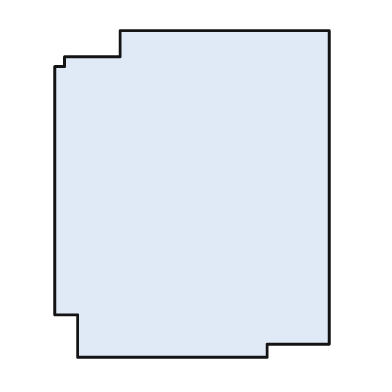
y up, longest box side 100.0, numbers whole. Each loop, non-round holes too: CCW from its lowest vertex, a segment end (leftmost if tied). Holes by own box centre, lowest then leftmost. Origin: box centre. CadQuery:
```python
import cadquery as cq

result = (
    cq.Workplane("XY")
    .moveTo(-35.0, -50.0)
    .lineTo(23.0, -50.0)
    .lineTo(23.0, -46.0)
    .lineTo(42.0, -46.0)
    .lineTo(42.0, 50.0)
    .lineTo(-22.0, 50.0)
    .lineTo(-22.0, 42.0)
    .lineTo(-39.0, 42.0)
    .lineTo(-39.0, 39.0)
    .lineTo(-42.0, 39.0)
    .lineTo(-42.0, -37.0)
    .lineTo(-35.0, -37.0)
    .close()
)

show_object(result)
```